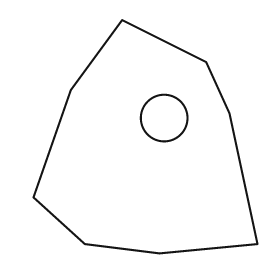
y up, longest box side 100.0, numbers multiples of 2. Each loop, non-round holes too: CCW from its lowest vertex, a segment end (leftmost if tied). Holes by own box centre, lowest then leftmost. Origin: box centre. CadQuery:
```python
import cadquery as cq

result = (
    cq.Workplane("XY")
    .moveTo(6.0, -50.0)
    .lineTo(48.0, -46.0)
    .lineTo(36.0, 10.0)
    .lineTo(26.0, 32.0)
    .lineTo(-10.0, 50.0)
    .lineTo(-32.0, 20.0)
    .lineTo(-48.0, -26.0)
    .lineTo(-26.0, -46.0)
    .close()
    .moveTo(8.0, 8.0)
    .circle(10.0)
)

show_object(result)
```